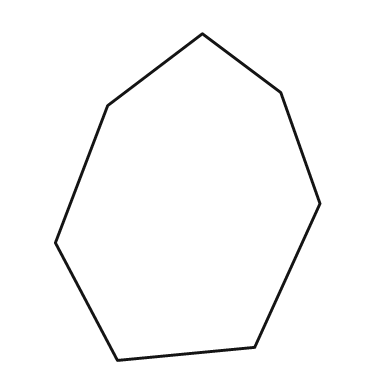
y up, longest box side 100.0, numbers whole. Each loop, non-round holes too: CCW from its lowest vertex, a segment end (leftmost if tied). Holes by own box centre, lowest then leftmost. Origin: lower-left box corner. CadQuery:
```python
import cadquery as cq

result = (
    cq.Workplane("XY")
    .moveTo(19.0, 0.0)
    .lineTo(61.0, 4.0)
    .lineTo(81.0, 48.0)
    .lineTo(69.0, 82.0)
    .lineTo(45.0, 100.0)
    .lineTo(16.0, 78.0)
    .lineTo(0.0, 36.0)
    .close()
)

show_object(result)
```